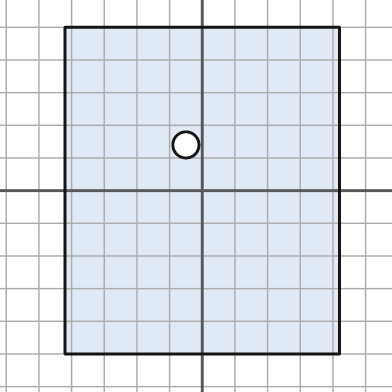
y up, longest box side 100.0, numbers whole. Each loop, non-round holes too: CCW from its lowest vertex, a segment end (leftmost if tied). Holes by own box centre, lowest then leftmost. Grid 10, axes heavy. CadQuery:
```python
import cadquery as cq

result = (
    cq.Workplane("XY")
    .moveTo(-42.0, -50.0)
    .lineTo(42.0, -50.0)
    .lineTo(42.0, 50.0)
    .lineTo(-42.0, 50.0)
    .close()
    .moveTo(-5.0, 14.0)
    .circle(4.0)
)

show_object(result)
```